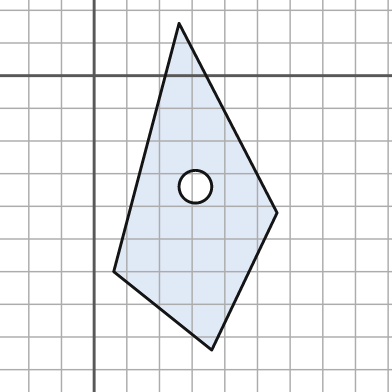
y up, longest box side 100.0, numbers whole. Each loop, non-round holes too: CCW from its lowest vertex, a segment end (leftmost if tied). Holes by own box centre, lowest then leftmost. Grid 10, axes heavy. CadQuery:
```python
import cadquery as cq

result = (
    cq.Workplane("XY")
    .moveTo(36.0, -84.0)
    .lineTo(56.0, -42.0)
    .lineTo(26.0, 16.0)
    .lineTo(6.0, -60.0)
    .close()
    .moveTo(31.0, -34.0)
    .circle(5.0)
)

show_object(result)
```